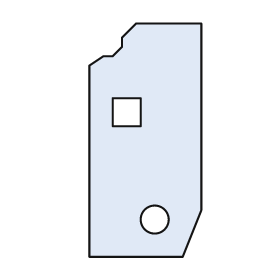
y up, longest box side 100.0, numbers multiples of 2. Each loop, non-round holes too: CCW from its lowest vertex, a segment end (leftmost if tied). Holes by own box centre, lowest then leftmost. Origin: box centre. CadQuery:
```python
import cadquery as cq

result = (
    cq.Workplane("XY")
    .moveTo(-24.0, -50.0)
    .lineTo(16.0, -50.0)
    .lineTo(24.0, -30.0)
    .lineTo(24.0, 50.0)
    .lineTo(-4.0, 50.0)
    .lineTo(-10.0, 44.0)
    .lineTo(-10.0, 40.0)
    .lineTo(-14.0, 36.0)
    .lineTo(-18.0, 36.0)
    .lineTo(-24.0, 32.0)
    .close()
    .moveTo(4.0, -34.0)
    .circle(6.0)
    .moveTo(-14.0, 6.0)
    .lineTo(-2.0, 6.0)
    .lineTo(-2.0, 18.0)
    .lineTo(-14.0, 18.0)
    .close()
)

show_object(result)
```